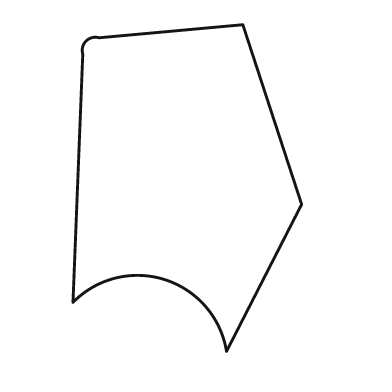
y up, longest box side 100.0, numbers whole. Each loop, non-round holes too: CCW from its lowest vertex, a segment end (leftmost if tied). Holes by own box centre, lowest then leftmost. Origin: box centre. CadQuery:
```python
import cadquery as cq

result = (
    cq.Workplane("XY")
    .moveTo(12.0, -50.0)
    .lineTo(35.0, -5.0)
    .lineTo(17.0, 50.0)
    .lineTo(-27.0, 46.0)
    .threePointArc((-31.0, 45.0), (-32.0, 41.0))
    .lineTo(-35.0, -35.0)
    .threePointArc((-7.0, -28.0), (12.0, -50.0))
    .close()
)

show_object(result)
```